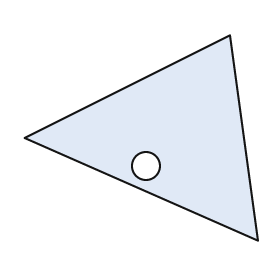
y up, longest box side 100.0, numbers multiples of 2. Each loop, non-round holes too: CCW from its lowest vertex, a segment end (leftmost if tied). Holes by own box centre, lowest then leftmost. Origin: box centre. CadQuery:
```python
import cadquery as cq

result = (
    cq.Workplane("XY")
    .moveTo(50.0, -44.0)
    .lineTo(38.0, 44.0)
    .lineTo(-50.0, 0.0)
    .close()
    .moveTo(2.0, -12.0)
    .circle(6.0)
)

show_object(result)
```